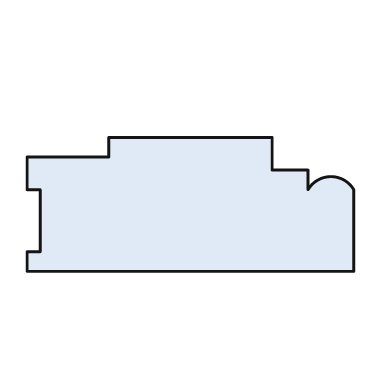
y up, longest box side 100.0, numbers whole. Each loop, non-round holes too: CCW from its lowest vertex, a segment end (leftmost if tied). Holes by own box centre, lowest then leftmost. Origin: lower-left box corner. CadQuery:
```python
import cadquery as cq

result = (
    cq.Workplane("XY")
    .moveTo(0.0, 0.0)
    .lineTo(100.0, 0.0)
    .lineTo(100.0, 25.0)
    .threePointArc((93.0, 29.0), (86.0, 25.0))
    .lineTo(86.0, 31.0)
    .lineTo(75.0, 31.0)
    .lineTo(75.0, 41.0)
    .lineTo(25.0, 41.0)
    .lineTo(25.0, 35.0)
    .lineTo(0.0, 35.0)
    .lineTo(0.0, 25.0)
    .lineTo(4.0, 25.0)
    .lineTo(4.0, 6.0)
    .lineTo(0.0, 6.0)
    .close()
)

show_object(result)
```